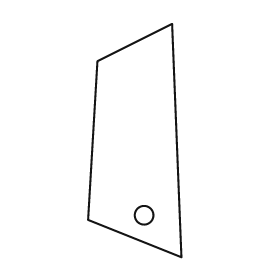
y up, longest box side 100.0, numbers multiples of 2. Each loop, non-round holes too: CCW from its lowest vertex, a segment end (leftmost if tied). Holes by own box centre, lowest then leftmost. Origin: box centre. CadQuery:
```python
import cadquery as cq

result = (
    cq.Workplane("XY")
    .moveTo(20.0, -50.0)
    .lineTo(16.0, 50.0)
    .lineTo(-16.0, 34.0)
    .lineTo(-20.0, -34.0)
    .close()
    .moveTo(4.0, -32.0)
    .circle(4.0)
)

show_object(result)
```